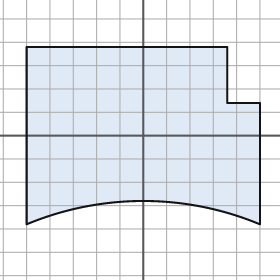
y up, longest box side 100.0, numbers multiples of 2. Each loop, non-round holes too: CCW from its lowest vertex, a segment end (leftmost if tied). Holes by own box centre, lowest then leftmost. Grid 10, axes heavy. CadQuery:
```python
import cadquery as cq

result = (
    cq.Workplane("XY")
    .moveTo(-50.0, -38.0)
    .threePointArc((0.0, -28.0), (50.0, -38.0))
    .lineTo(50.0, 14.0)
    .lineTo(36.0, 14.0)
    .lineTo(36.0, 38.0)
    .lineTo(-50.0, 38.0)
    .close()
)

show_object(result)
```